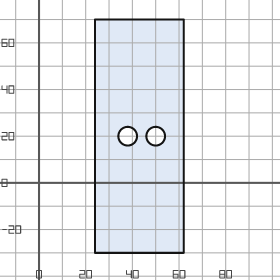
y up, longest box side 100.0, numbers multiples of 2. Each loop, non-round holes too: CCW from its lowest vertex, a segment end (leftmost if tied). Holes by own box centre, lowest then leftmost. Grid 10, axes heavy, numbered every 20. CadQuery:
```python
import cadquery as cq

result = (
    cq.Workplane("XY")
    .moveTo(24.0, -30.0)
    .lineTo(62.0, -30.0)
    .lineTo(62.0, 70.0)
    .lineTo(24.0, 70.0)
    .close()
    .moveTo(38.0, 20.0)
    .circle(4.0)
    .moveTo(50.0, 20.0)
    .circle(4.0)
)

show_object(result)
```